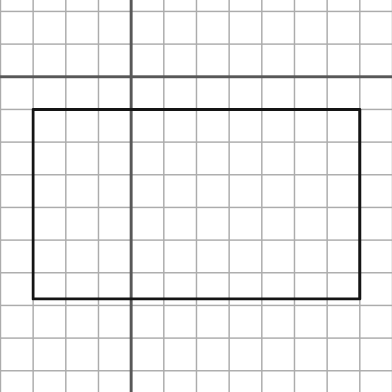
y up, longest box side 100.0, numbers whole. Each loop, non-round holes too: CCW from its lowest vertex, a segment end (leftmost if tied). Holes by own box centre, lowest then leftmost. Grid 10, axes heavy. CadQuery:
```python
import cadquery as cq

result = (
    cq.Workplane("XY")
    .moveTo(-30.0, -68.0)
    .lineTo(70.0, -68.0)
    .lineTo(70.0, -10.0)
    .lineTo(-30.0, -10.0)
    .close()
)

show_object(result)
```